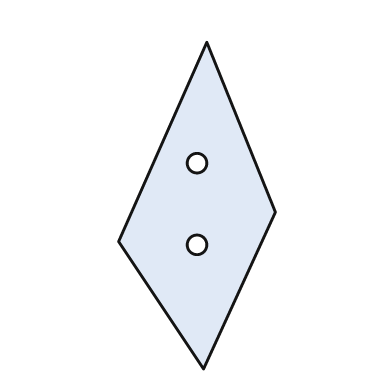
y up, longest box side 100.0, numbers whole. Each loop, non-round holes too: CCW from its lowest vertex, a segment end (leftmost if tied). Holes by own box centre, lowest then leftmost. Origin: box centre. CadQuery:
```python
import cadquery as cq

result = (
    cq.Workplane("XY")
    .moveTo(2.0, -50.0)
    .lineTo(24.0, -2.0)
    .lineTo(3.0, 50.0)
    .lineTo(-24.0, -11.0)
    .close()
    .moveTo(0.0, -12.0)
    .circle(3.0)
    .moveTo(0.0, 13.0)
    .circle(3.0)
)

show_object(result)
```